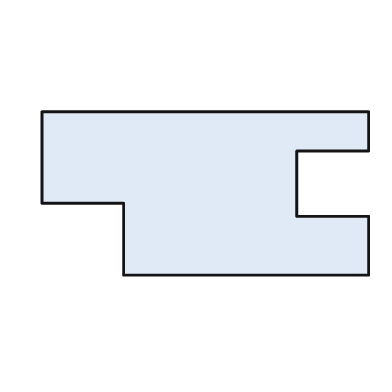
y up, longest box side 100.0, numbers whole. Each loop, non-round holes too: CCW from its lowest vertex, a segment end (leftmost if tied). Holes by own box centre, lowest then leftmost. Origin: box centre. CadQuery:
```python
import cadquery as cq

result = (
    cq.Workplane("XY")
    .moveTo(-25.0, -25.0)
    .lineTo(50.0, -25.0)
    .lineTo(50.0, -7.0)
    .lineTo(28.0, -7.0)
    .lineTo(28.0, 13.0)
    .lineTo(50.0, 13.0)
    .lineTo(50.0, 25.0)
    .lineTo(-50.0, 25.0)
    .lineTo(-50.0, -3.0)
    .lineTo(-25.0, -3.0)
    .close()
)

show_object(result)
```